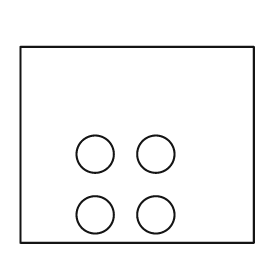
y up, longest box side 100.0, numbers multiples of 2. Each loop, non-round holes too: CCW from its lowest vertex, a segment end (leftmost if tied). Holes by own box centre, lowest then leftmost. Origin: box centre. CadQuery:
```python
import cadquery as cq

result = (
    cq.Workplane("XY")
    .moveTo(-50.0, -42.0)
    .lineTo(50.0, -42.0)
    .lineTo(50.0, 42.0)
    .lineTo(-50.0, 42.0)
    .close()
    .moveTo(-18.0, -30.0)
    .circle(8.0)
    .moveTo(8.0, -30.0)
    .circle(8.0)
    .moveTo(-18.0, -4.0)
    .circle(8.0)
    .moveTo(8.0, -4.0)
    .circle(8.0)
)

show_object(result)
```